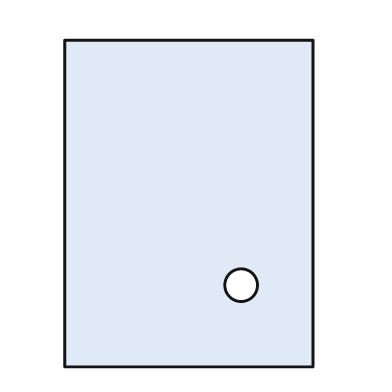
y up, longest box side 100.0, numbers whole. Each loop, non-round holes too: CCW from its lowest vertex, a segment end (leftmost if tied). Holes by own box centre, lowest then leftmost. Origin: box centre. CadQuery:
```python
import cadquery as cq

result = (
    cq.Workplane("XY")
    .moveTo(-38.0, -50.0)
    .lineTo(38.0, -50.0)
    .lineTo(38.0, 50.0)
    .lineTo(-38.0, 50.0)
    .close()
    .moveTo(16.0, -25.0)
    .circle(5.0)
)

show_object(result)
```